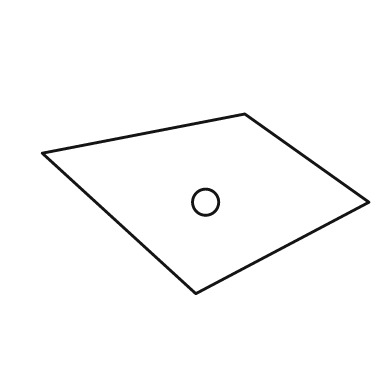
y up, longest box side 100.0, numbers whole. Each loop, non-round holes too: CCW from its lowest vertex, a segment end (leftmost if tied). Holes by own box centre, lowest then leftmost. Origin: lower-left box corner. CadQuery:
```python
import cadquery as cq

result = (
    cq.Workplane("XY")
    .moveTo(47.0, 0.0)
    .lineTo(100.0, 28.0)
    .lineTo(62.0, 55.0)
    .lineTo(0.0, 43.0)
    .close()
    .moveTo(50.0, 28.0)
    .circle(4.0)
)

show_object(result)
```